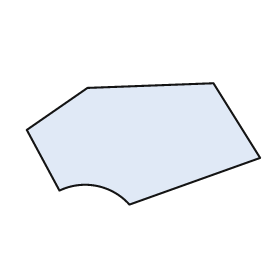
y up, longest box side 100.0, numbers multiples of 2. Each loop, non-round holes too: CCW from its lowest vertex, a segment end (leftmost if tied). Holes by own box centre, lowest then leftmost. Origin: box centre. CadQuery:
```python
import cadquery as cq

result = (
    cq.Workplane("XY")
    .moveTo(-6.0, -26.0)
    .lineTo(50.0, -6.0)
    .lineTo(30.0, 26.0)
    .lineTo(-24.0, 24.0)
    .lineTo(-50.0, 6.0)
    .lineTo(-36.0, -20.0)
    .threePointArc((-20.0, -18.0), (-6.0, -26.0))
    .close()
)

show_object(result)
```